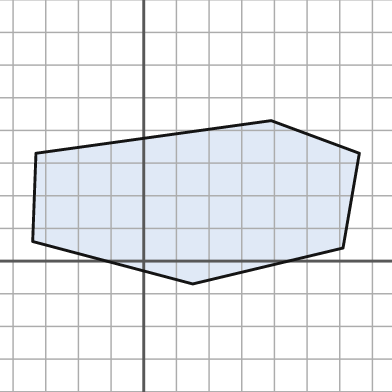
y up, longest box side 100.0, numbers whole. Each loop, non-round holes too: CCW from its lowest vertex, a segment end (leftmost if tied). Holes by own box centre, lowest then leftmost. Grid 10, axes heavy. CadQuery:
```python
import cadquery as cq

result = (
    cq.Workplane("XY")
    .moveTo(15.0, -7.0)
    .lineTo(61.0, 4.0)
    .lineTo(66.0, 33.0)
    .lineTo(39.0, 43.0)
    .lineTo(-33.0, 33.0)
    .lineTo(-34.0, 6.0)
    .close()
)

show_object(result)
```